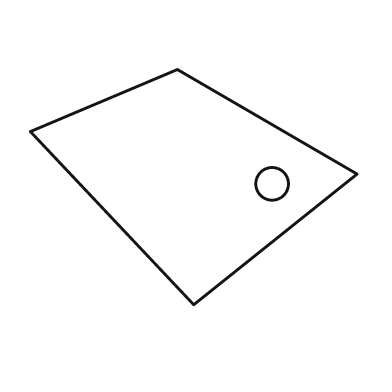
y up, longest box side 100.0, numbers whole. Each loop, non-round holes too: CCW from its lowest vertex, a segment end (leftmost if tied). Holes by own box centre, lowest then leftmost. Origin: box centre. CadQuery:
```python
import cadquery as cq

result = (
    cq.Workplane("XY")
    .moveTo(0.0, -36.0)
    .lineTo(50.0, 4.0)
    .lineTo(-5.0, 36.0)
    .lineTo(-50.0, 17.0)
    .close()
    .moveTo(24.0, 1.0)
    .circle(5.0)
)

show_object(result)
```